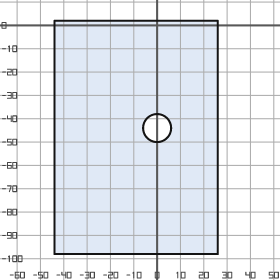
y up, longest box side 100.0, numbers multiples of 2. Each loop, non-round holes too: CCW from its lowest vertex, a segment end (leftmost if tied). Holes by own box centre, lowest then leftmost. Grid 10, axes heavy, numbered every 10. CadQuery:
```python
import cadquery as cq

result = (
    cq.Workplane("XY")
    .moveTo(-44.0, -98.0)
    .lineTo(26.0, -98.0)
    .lineTo(26.0, 2.0)
    .lineTo(-44.0, 2.0)
    .close()
    .moveTo(0.0, -44.0)
    .circle(6.0)
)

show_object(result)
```